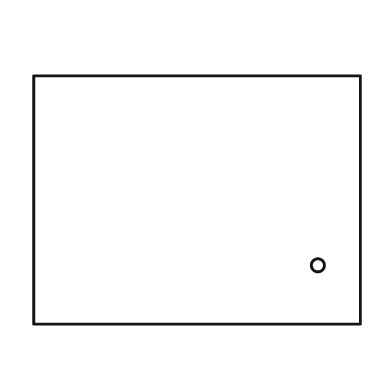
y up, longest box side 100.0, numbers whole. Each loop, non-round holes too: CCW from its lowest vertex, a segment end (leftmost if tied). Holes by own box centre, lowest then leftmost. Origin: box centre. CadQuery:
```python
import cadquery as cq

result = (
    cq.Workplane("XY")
    .moveTo(-50.0, -38.0)
    .lineTo(50.0, -38.0)
    .lineTo(50.0, 38.0)
    .lineTo(-50.0, 38.0)
    .close()
    .moveTo(37.0, -20.0)
    .circle(2.0)
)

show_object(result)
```